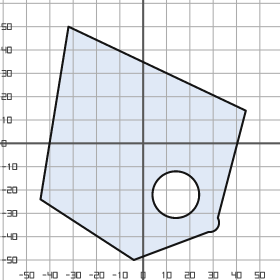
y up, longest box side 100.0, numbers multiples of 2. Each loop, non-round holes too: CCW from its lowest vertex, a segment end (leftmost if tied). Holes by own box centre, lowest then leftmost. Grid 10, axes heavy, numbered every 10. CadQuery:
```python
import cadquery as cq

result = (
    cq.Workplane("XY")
    .moveTo(-4.0, -50.0)
    .lineTo(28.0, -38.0)
    .threePointArc((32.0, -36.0), (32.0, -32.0))
    .lineTo(44.0, 14.0)
    .lineTo(-32.0, 50.0)
    .lineTo(-44.0, -24.0)
    .close()
    .moveTo(14.0, -22.0)
    .circle(10.0)
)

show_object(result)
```